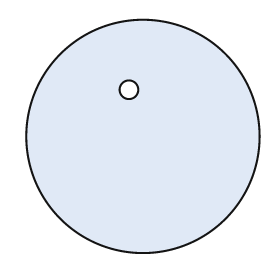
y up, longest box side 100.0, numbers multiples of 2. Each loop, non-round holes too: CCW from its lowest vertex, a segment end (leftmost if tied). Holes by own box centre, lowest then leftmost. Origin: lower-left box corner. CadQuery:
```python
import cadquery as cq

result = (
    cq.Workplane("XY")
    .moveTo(50.0, 50.0)
    .circle(50.0)
    .moveTo(44.0, 70.0)
    .circle(4.0)
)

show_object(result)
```